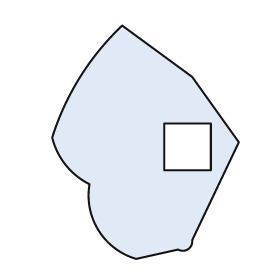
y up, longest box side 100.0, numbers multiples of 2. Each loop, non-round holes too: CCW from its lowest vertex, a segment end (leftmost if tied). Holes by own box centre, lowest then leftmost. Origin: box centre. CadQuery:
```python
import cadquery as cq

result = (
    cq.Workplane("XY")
    .moveTo(-4.0, -50.0)
    .lineTo(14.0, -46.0)
    .threePointArc((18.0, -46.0), (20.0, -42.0))
    .lineTo(40.0, 0.0)
    .lineTo(20.0, 28.0)
    .lineTo(-10.0, 50.0)
    .threePointArc((-28.0, 28.0), (-40.0, 2.0))
    .threePointArc((-34.0, -10.0), (-24.0, -18.0))
    .threePointArc((-20.0, -38.0), (-4.0, -50.0))
    .close()
    .moveTo(8.0, -12.0)
    .lineTo(28.0, -12.0)
    .lineTo(28.0, 8.0)
    .lineTo(8.0, 8.0)
    .close()
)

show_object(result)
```